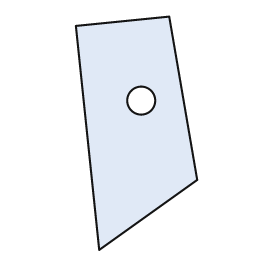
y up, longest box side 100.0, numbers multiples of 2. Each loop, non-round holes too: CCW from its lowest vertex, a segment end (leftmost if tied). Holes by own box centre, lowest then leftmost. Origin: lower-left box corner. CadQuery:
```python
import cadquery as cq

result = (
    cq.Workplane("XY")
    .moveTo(10.0, 0.0)
    .lineTo(52.0, 30.0)
    .lineTo(40.0, 100.0)
    .lineTo(0.0, 96.0)
    .close()
    .moveTo(28.0, 64.0)
    .circle(6.0)
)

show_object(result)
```